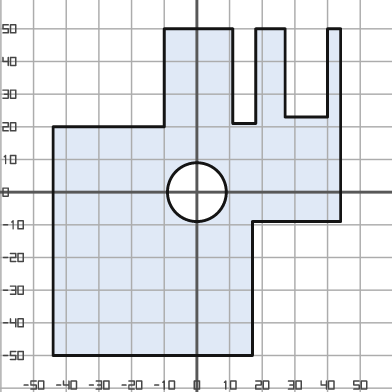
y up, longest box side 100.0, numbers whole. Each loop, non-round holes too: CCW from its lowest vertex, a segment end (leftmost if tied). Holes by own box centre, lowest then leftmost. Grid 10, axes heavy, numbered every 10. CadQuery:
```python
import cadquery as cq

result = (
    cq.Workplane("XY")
    .moveTo(-44.0, -50.0)
    .lineTo(17.0, -50.0)
    .lineTo(17.0, -9.0)
    .lineTo(44.0, -9.0)
    .lineTo(44.0, 50.0)
    .lineTo(40.0, 50.0)
    .lineTo(40.0, 23.0)
    .lineTo(27.0, 23.0)
    .lineTo(27.0, 50.0)
    .lineTo(18.0, 50.0)
    .lineTo(18.0, 21.0)
    .lineTo(11.0, 21.0)
    .lineTo(11.0, 50.0)
    .lineTo(-10.0, 50.0)
    .lineTo(-10.0, 20.0)
    .lineTo(-44.0, 20.0)
    .close()
    .moveTo(0.0, 0.0)
    .circle(9.0)
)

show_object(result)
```